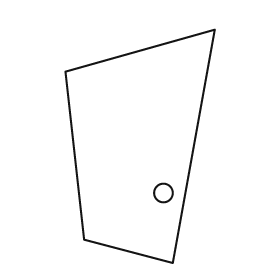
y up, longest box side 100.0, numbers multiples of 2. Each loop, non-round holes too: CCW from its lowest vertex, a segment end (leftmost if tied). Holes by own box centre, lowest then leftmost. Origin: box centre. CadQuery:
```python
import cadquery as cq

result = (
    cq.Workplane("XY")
    .moveTo(14.0, -50.0)
    .lineTo(32.0, 50.0)
    .lineTo(-32.0, 32.0)
    .lineTo(-24.0, -40.0)
    .close()
    .moveTo(10.0, -20.0)
    .circle(4.0)
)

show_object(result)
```